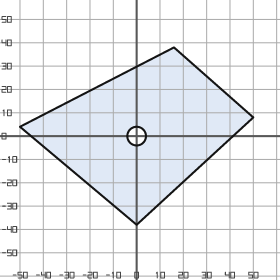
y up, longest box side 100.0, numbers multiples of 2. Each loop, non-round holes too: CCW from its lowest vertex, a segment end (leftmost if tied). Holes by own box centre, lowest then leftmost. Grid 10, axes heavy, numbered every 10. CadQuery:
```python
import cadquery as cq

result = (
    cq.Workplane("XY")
    .moveTo(0.0, -38.0)
    .lineTo(50.0, 8.0)
    .lineTo(16.0, 38.0)
    .lineTo(-50.0, 4.0)
    .close()
    .moveTo(0.0, 0.0)
    .circle(4.0)
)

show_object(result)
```